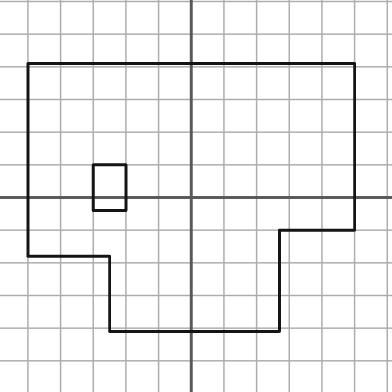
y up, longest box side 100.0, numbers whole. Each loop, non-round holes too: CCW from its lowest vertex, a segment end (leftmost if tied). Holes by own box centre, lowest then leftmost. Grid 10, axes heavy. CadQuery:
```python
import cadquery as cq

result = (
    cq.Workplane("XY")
    .moveTo(-25.0, -41.0)
    .lineTo(27.0, -41.0)
    .lineTo(27.0, -10.0)
    .lineTo(50.0, -10.0)
    .lineTo(50.0, 41.0)
    .lineTo(-50.0, 41.0)
    .lineTo(-50.0, -18.0)
    .lineTo(-25.0, -18.0)
    .close()
    .moveTo(-30.0, -4.0)
    .lineTo(-20.0, -4.0)
    .lineTo(-20.0, 10.0)
    .lineTo(-30.0, 10.0)
    .close()
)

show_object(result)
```